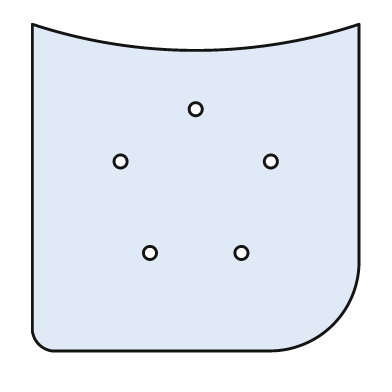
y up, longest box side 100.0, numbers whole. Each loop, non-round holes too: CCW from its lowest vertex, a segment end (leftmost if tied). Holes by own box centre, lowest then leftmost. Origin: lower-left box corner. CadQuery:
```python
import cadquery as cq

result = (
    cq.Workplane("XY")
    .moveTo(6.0, 0.0)
    .lineTo(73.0, 0.0)
    .threePointArc((92.0, 8.0), (100.0, 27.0))
    .lineTo(100.0, 100.0)
    .threePointArc((50.0, 92.0), (0.0, 100.0))
    .lineTo(0.0, 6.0)
    .threePointArc((2.0, 2.0), (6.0, 0.0))
    .close()
    .moveTo(36.0, 30.0)
    .circle(2.0)
    .moveTo(64.0, 30.0)
    .circle(2.0)
    .moveTo(27.0, 58.0)
    .circle(2.0)
    .moveTo(73.0, 58.0)
    .circle(2.0)
    .moveTo(50.0, 74.0)
    .circle(2.0)
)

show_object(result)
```